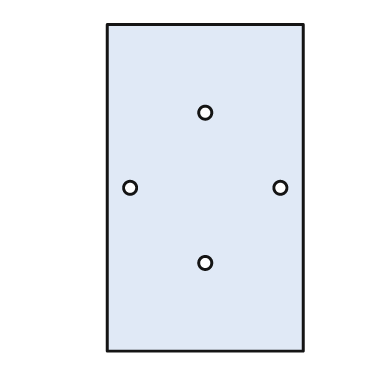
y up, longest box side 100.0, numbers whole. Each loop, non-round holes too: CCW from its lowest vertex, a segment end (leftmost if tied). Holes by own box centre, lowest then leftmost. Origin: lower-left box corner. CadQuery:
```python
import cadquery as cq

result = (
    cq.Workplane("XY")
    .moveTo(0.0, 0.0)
    .lineTo(60.0, 0.0)
    .lineTo(60.0, 100.0)
    .lineTo(0.0, 100.0)
    .close()
    .moveTo(30.0, 27.0)
    .circle(2.0)
    .moveTo(7.0, 50.0)
    .circle(2.0)
    .moveTo(53.0, 50.0)
    .circle(2.0)
    .moveTo(30.0, 73.0)
    .circle(2.0)
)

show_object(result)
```